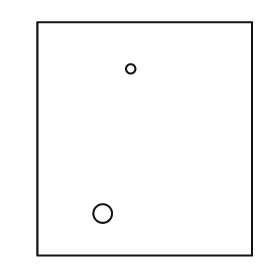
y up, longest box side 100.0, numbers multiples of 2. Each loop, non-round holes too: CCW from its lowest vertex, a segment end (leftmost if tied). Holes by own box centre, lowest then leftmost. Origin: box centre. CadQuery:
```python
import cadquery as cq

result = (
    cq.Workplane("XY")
    .moveTo(-46.0, -50.0)
    .lineTo(46.0, -50.0)
    .lineTo(46.0, 50.0)
    .lineTo(-46.0, 50.0)
    .close()
    .moveTo(-18.0, -32.0)
    .circle(4.0)
    .moveTo(-6.0, 30.0)
    .circle(2.0)
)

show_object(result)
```